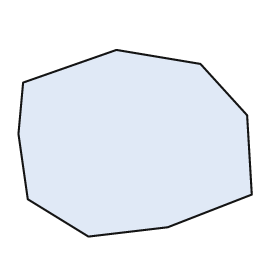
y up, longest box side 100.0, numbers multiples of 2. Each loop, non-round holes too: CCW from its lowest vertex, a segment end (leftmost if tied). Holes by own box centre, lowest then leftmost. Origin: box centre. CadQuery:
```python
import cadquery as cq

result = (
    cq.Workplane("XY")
    .moveTo(-20.0, -40.0)
    .lineTo(14.0, -36.0)
    .lineTo(50.0, -22.0)
    .lineTo(48.0, 12.0)
    .lineTo(28.0, 34.0)
    .lineTo(-8.0, 40.0)
    .lineTo(-48.0, 26.0)
    .lineTo(-50.0, 4.0)
    .lineTo(-46.0, -24.0)
    .close()
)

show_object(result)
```